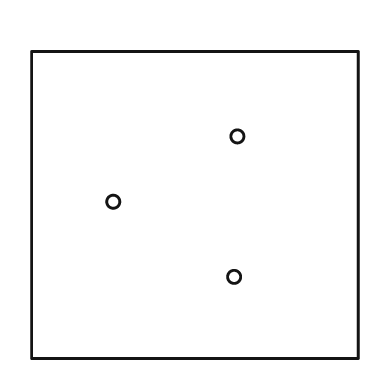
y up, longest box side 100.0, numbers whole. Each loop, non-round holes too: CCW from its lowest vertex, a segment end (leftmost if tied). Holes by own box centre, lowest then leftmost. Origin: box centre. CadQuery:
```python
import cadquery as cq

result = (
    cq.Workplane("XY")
    .moveTo(-50.0, -47.0)
    .lineTo(50.0, -47.0)
    .lineTo(50.0, 47.0)
    .lineTo(-50.0, 47.0)
    .close()
    .moveTo(12.0, -22.0)
    .circle(2.0)
    .moveTo(-25.0, 1.0)
    .circle(2.0)
    .moveTo(13.0, 21.0)
    .circle(2.0)
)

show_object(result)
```